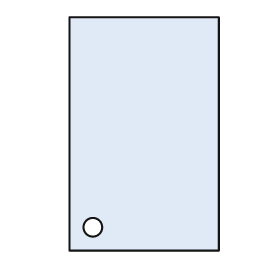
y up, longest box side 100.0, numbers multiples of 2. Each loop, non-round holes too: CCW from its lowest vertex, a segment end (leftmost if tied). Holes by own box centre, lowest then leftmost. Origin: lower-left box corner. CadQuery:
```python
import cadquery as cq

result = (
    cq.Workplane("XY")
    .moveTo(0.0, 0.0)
    .lineTo(64.0, 0.0)
    .lineTo(64.0, 100.0)
    .lineTo(0.0, 100.0)
    .close()
    .moveTo(10.0, 10.0)
    .circle(4.0)
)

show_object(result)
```